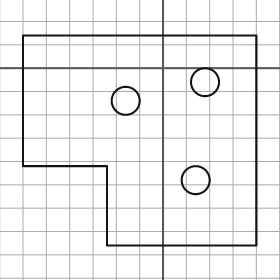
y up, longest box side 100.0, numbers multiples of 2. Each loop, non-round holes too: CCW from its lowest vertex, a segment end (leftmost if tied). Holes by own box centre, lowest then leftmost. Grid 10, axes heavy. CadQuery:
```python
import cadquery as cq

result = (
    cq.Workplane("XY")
    .moveTo(-24.0, -76.0)
    .lineTo(40.0, -76.0)
    .lineTo(40.0, 14.0)
    .lineTo(-60.0, 14.0)
    .lineTo(-60.0, -42.0)
    .lineTo(-24.0, -42.0)
    .close()
    .moveTo(14.0, -48.0)
    .circle(6.0)
    .moveTo(-16.0, -14.0)
    .circle(6.0)
    .moveTo(18.0, -6.0)
    .circle(6.0)
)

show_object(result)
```